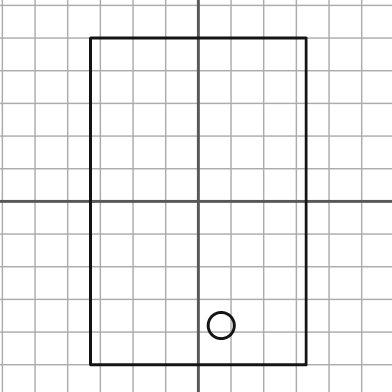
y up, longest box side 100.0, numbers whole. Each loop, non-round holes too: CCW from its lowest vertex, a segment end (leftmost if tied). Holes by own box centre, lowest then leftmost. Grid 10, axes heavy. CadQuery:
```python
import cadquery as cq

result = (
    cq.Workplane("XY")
    .moveTo(-33.0, -50.0)
    .lineTo(33.0, -50.0)
    .lineTo(33.0, 50.0)
    .lineTo(-33.0, 50.0)
    .close()
    .moveTo(7.0, -38.0)
    .circle(4.0)
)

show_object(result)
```